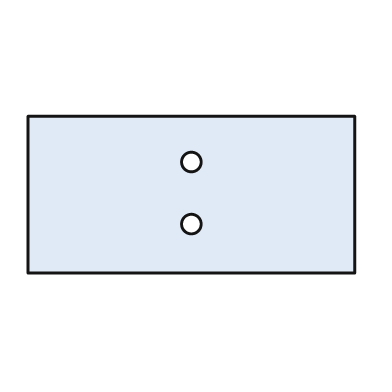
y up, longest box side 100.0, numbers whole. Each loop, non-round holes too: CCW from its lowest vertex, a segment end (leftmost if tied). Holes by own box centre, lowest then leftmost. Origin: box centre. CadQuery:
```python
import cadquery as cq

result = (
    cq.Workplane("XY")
    .moveTo(-50.0, -24.0)
    .lineTo(50.0, -24.0)
    .lineTo(50.0, 24.0)
    .lineTo(-50.0, 24.0)
    .close()
    .moveTo(0.0, -9.0)
    .circle(3.0)
    .moveTo(0.0, 10.0)
    .circle(3.0)
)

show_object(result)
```